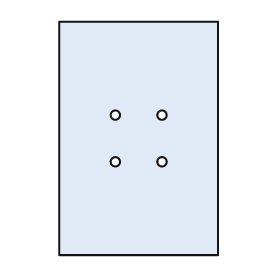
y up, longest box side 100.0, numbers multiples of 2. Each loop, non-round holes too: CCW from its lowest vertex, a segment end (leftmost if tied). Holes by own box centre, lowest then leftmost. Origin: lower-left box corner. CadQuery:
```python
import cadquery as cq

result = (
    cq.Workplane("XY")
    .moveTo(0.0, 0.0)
    .lineTo(68.0, 0.0)
    .lineTo(68.0, 100.0)
    .lineTo(0.0, 100.0)
    .close()
    .moveTo(24.0, 40.0)
    .circle(2.0)
    .moveTo(44.0, 40.0)
    .circle(2.0)
    .moveTo(24.0, 60.0)
    .circle(2.0)
    .moveTo(44.0, 60.0)
    .circle(2.0)
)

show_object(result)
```